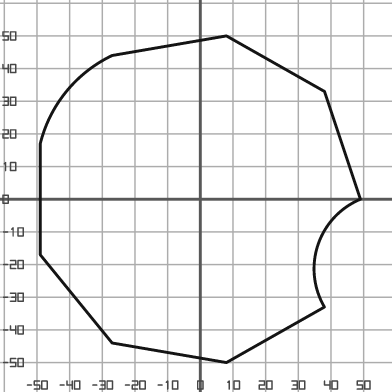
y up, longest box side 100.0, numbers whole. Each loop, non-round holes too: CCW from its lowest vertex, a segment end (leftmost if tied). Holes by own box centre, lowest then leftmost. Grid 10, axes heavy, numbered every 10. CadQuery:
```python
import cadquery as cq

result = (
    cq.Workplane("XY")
    .moveTo(8.0, -50.0)
    .lineTo(38.0, -33.0)
    .threePointArc((36.0, -14.0), (49.0, 0.0))
    .lineTo(38.0, 33.0)
    .lineTo(8.0, 50.0)
    .lineTo(-27.0, 44.0)
    .threePointArc((-41.0, 33.0), (-49.0, 17.0))
    .lineTo(-49.0, -17.0)
    .lineTo(-27.0, -44.0)
    .close()
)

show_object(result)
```